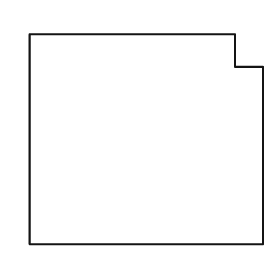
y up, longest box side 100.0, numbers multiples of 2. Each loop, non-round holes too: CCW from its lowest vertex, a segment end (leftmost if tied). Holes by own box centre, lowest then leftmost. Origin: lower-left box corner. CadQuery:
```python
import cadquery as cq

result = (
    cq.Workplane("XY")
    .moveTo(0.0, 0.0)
    .lineTo(100.0, 0.0)
    .lineTo(100.0, 76.0)
    .lineTo(88.0, 76.0)
    .lineTo(88.0, 90.0)
    .lineTo(0.0, 90.0)
    .close()
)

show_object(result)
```